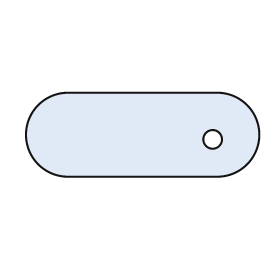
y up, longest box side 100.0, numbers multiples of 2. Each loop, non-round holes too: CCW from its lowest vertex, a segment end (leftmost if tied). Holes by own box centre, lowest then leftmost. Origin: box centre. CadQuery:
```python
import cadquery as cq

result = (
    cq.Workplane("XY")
    .moveTo(-32.0, -18.0)
    .lineTo(32.0, -18.0)
    .threePointArc((50.0, 0.0), (32.0, 18.0))
    .lineTo(-32.0, 18.0)
    .threePointArc((-50.0, 0.0), (-32.0, -18.0))
    .close()
    .moveTo(30.0, -2.0)
    .circle(4.0)
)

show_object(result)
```